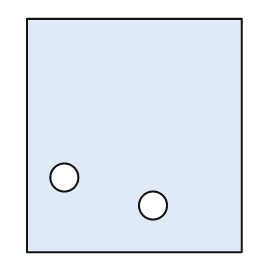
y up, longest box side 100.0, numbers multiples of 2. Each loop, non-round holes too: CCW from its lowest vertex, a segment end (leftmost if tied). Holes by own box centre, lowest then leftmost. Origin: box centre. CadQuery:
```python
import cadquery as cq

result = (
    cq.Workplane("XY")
    .moveTo(-46.0, -50.0)
    .lineTo(46.0, -50.0)
    .lineTo(46.0, 50.0)
    .lineTo(-46.0, 50.0)
    .close()
    .moveTo(8.0, -30.0)
    .circle(6.0)
    .moveTo(-30.0, -18.0)
    .circle(6.0)
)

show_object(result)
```